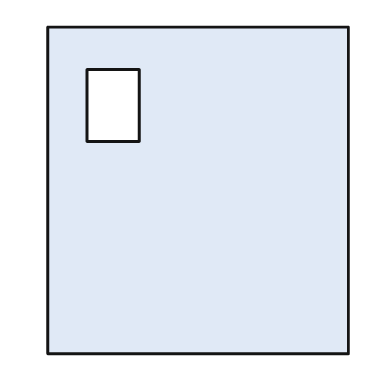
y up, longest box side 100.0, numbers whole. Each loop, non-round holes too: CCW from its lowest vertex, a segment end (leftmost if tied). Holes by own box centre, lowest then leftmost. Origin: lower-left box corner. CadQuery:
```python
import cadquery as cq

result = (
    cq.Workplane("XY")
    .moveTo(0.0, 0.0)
    .lineTo(92.0, 0.0)
    .lineTo(92.0, 100.0)
    .lineTo(0.0, 100.0)
    .close()
    .moveTo(12.0, 65.0)
    .lineTo(28.0, 65.0)
    .lineTo(28.0, 87.0)
    .lineTo(12.0, 87.0)
    .close()
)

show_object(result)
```